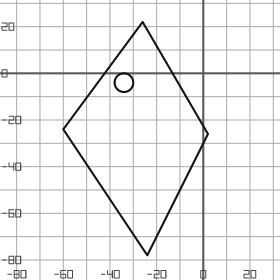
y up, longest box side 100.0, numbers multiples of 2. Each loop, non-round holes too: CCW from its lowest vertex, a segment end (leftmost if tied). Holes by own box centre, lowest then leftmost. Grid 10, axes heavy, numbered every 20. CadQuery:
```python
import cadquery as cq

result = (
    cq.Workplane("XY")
    .moveTo(-24.0, -78.0)
    .lineTo(2.0, -26.0)
    .lineTo(-26.0, 22.0)
    .lineTo(-60.0, -24.0)
    .close()
    .moveTo(-34.0, -4.0)
    .circle(4.0)
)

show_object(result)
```